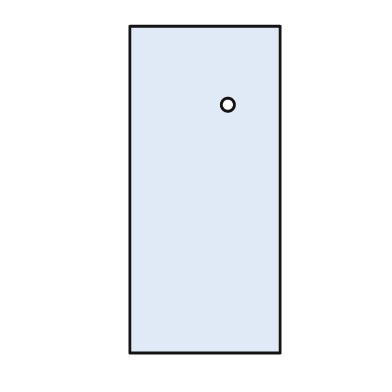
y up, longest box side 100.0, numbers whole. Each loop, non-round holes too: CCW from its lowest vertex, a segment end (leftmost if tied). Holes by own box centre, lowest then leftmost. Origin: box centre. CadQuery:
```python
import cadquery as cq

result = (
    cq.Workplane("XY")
    .moveTo(-23.0, -50.0)
    .lineTo(23.0, -50.0)
    .lineTo(23.0, 50.0)
    .lineTo(-23.0, 50.0)
    .close()
    .moveTo(7.0, 26.0)
    .circle(2.0)
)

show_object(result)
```